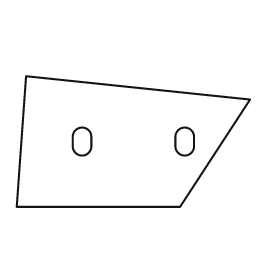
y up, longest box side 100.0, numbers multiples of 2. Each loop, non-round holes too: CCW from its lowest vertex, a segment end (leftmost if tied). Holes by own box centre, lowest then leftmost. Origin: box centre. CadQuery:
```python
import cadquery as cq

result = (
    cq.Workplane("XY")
    .moveTo(-50.0, -28.0)
    .lineTo(20.0, -28.0)
    .lineTo(50.0, 18.0)
    .lineTo(-46.0, 28.0)
    .close()
    .moveTo(-26.0, -2.0)
    .threePointArc((-22.0, -6.0), (-18.0, -2.0))
    .lineTo(-18.0, 2.0)
    .threePointArc((-22.0, 6.0), (-26.0, 2.0))
    .close()
    .moveTo(18.0, -2.0)
    .threePointArc((22.0, -6.0), (26.0, -2.0))
    .lineTo(26.0, 2.0)
    .threePointArc((22.0, 6.0), (18.0, 2.0))
    .close()
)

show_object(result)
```